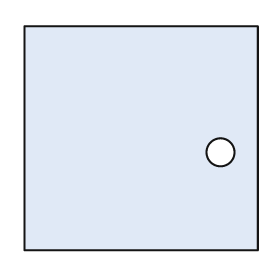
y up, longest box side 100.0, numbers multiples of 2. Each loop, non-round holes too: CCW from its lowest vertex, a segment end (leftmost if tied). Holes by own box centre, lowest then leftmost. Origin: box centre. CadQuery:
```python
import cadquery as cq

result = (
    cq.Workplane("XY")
    .moveTo(-50.0, -48.0)
    .lineTo(50.0, -48.0)
    .lineTo(50.0, 48.0)
    .lineTo(-50.0, 48.0)
    .close()
    .moveTo(34.0, -6.0)
    .circle(6.0)
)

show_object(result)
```